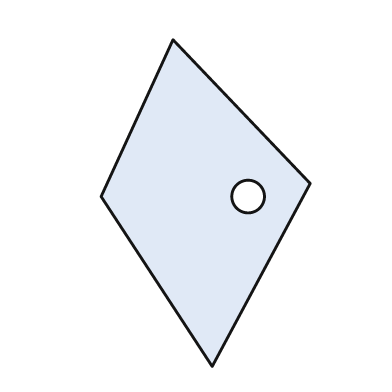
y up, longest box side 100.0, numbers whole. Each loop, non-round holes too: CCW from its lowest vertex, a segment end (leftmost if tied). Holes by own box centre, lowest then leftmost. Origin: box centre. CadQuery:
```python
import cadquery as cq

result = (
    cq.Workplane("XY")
    .moveTo(2.0, -50.0)
    .lineTo(32.0, 6.0)
    .lineTo(-10.0, 50.0)
    .lineTo(-32.0, 2.0)
    .close()
    .moveTo(13.0, 2.0)
    .circle(5.0)
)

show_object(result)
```